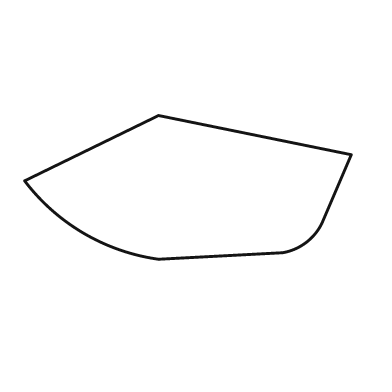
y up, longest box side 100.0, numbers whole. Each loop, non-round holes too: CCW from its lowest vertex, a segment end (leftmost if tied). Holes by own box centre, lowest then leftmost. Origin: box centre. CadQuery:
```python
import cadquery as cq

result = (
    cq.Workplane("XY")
    .moveTo(-9.0, -22.0)
    .lineTo(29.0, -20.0)
    .threePointArc((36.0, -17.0), (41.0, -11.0))
    .lineTo(50.0, 10.0)
    .lineTo(-9.0, 22.0)
    .lineTo(-50.0, 2.0)
    .threePointArc((-32.0, -14.0), (-9.0, -22.0))
    .close()
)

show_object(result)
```